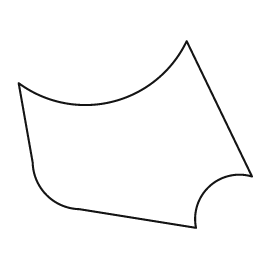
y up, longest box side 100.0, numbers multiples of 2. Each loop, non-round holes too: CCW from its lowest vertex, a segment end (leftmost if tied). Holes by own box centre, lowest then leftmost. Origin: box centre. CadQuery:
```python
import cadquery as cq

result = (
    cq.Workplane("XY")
    .moveTo(26.0, -40.0)
    .threePointArc((32.0, -22.0), (50.0, -18.0))
    .lineTo(22.0, 40.0)
    .threePointArc((-10.0, 14.0), (-50.0, 22.0))
    .lineTo(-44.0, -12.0)
    .threePointArc((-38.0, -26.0), (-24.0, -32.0))
    .close()
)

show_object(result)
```